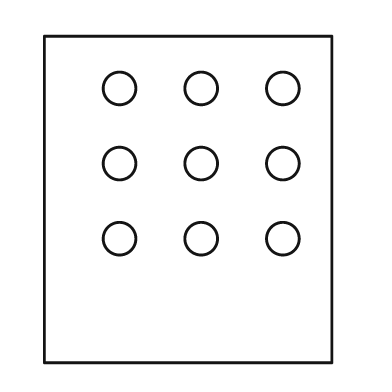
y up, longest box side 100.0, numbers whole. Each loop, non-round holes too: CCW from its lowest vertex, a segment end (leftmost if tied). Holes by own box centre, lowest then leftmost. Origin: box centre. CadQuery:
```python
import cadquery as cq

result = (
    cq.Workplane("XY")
    .moveTo(-44.0, -50.0)
    .lineTo(44.0, -50.0)
    .lineTo(44.0, 50.0)
    .lineTo(-44.0, 50.0)
    .close()
    .moveTo(-21.0, -12.0)
    .circle(5.0)
    .moveTo(4.0, -12.0)
    .circle(5.0)
    .moveTo(29.0, -12.0)
    .circle(5.0)
    .moveTo(-21.0, 11.0)
    .circle(5.0)
    .moveTo(4.0, 11.0)
    .circle(5.0)
    .moveTo(29.0, 11.0)
    .circle(5.0)
    .moveTo(-21.0, 34.0)
    .circle(5.0)
    .moveTo(4.0, 34.0)
    .circle(5.0)
    .moveTo(29.0, 34.0)
    .circle(5.0)
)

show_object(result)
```